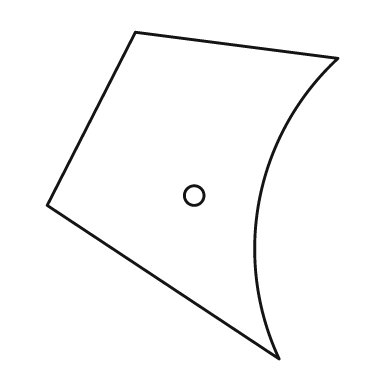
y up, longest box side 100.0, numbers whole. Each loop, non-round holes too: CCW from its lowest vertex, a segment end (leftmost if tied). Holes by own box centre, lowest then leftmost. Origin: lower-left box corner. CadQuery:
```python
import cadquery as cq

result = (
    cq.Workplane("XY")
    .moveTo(71.0, 0.0)
    .threePointArc((65.0, 49.0), (89.0, 92.0))
    .lineTo(27.0, 100.0)
    .lineTo(0.0, 47.0)
    .close()
    .moveTo(45.0, 50.0)
    .circle(3.0)
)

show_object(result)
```